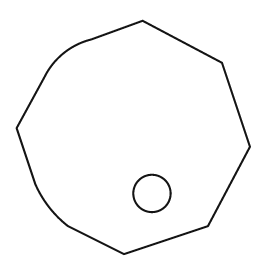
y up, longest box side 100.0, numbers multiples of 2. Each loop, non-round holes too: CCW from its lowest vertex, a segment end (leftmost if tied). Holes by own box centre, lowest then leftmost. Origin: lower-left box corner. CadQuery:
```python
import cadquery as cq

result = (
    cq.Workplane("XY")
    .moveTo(46.0, 0.0)
    .lineTo(82.0, 12.0)
    .lineTo(100.0, 46.0)
    .lineTo(88.0, 82.0)
    .lineTo(54.0, 100.0)
    .lineTo(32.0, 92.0)
    .threePointArc((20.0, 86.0), (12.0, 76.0))
    .lineTo(0.0, 54.0)
    .lineTo(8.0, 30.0)
    .threePointArc((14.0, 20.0), (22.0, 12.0))
    .close()
    .moveTo(58.0, 26.0)
    .circle(8.0)
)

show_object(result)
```